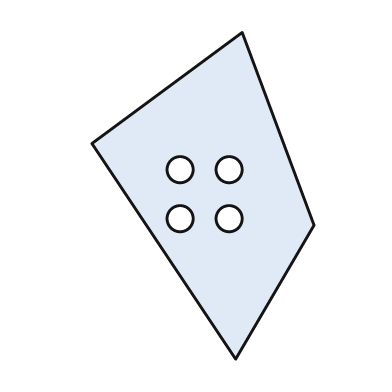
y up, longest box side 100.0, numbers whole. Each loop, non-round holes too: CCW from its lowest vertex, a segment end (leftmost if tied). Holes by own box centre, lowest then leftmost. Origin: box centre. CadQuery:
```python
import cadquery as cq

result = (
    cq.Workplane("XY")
    .moveTo(10.0, -50.0)
    .lineTo(34.0, -9.0)
    .lineTo(12.0, 50.0)
    .lineTo(-34.0, 16.0)
    .close()
    .moveTo(-7.0, -7.0)
    .circle(4.0)
    .moveTo(8.0, -7.0)
    .circle(4.0)
    .moveTo(-7.0, 8.0)
    .circle(4.0)
    .moveTo(8.0, 8.0)
    .circle(4.0)
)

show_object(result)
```